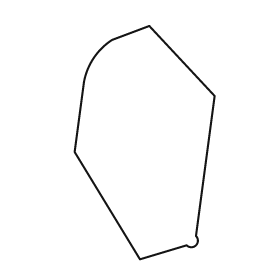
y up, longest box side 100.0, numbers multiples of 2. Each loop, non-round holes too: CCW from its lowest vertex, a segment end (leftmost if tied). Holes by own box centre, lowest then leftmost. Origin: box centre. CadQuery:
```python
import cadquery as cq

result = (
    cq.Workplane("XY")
    .moveTo(-2.0, -50.0)
    .lineTo(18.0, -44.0)
    .threePointArc((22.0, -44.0), (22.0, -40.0))
    .lineTo(30.0, 20.0)
    .lineTo(2.0, 50.0)
    .lineTo(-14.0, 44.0)
    .threePointArc((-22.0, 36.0), (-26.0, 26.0))
    .lineTo(-30.0, -4.0)
    .close()
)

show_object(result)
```